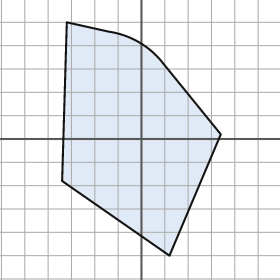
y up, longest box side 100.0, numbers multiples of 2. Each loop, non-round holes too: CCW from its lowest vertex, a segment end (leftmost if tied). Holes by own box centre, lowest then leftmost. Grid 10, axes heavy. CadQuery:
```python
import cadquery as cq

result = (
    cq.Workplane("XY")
    .moveTo(12.0, -50.0)
    .lineTo(34.0, 2.0)
    .lineTo(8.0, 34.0)
    .threePointArc((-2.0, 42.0), (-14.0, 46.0))
    .lineTo(-32.0, 50.0)
    .lineTo(-34.0, -18.0)
    .close()
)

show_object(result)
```